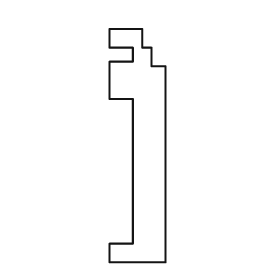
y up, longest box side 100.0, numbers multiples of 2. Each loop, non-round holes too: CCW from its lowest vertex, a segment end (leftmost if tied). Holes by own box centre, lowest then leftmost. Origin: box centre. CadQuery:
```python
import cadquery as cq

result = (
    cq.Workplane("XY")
    .moveTo(-12.0, -50.0)
    .lineTo(12.0, -50.0)
    .lineTo(12.0, 34.0)
    .lineTo(6.0, 34.0)
    .lineTo(6.0, 42.0)
    .lineTo(2.0, 42.0)
    .lineTo(2.0, 50.0)
    .lineTo(-12.0, 50.0)
    .lineTo(-12.0, 42.0)
    .lineTo(-2.0, 42.0)
    .lineTo(-2.0, 36.0)
    .lineTo(-12.0, 36.0)
    .lineTo(-12.0, 20.0)
    .lineTo(-2.0, 20.0)
    .lineTo(-2.0, -42.0)
    .lineTo(-12.0, -42.0)
    .close()
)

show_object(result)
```